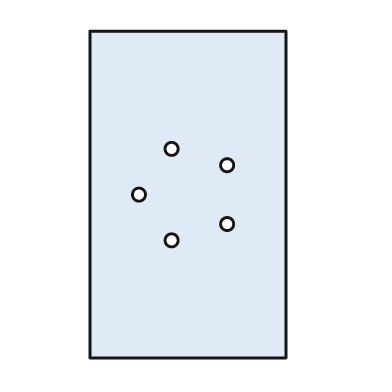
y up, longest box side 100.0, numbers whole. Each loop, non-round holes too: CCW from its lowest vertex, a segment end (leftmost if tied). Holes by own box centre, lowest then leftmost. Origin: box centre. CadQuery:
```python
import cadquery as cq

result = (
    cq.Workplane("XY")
    .moveTo(-30.0, -50.0)
    .lineTo(30.0, -50.0)
    .lineTo(30.0, 50.0)
    .lineTo(-30.0, 50.0)
    .close()
    .moveTo(-5.0, -14.0)
    .circle(2.0)
    .moveTo(12.0, -9.0)
    .circle(2.0)
    .moveTo(-15.0, 0.0)
    .circle(2.0)
    .moveTo(12.0, 9.0)
    .circle(2.0)
    .moveTo(-5.0, 14.0)
    .circle(2.0)
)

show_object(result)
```